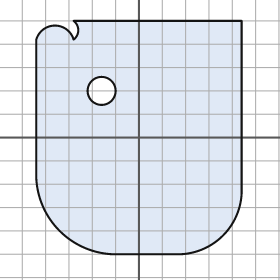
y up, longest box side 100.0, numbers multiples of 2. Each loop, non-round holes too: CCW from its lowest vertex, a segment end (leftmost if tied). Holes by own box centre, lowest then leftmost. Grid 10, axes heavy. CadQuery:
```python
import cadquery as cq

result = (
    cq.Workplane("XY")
    .moveTo(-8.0, -50.0)
    .lineTo(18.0, -50.0)
    .threePointArc((36.0, -42.0), (44.0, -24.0))
    .lineTo(44.0, 50.0)
    .lineTo(-28.0, 50.0)
    .threePointArc((-26.0, 46.0), (-28.0, 42.0))
    .threePointArc((-36.0, 48.0), (-44.0, 42.0))
    .lineTo(-44.0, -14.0)
    .threePointArc((-34.0, -40.0), (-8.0, -50.0))
    .close()
    .moveTo(-16.0, 20.0)
    .circle(6.0)
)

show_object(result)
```